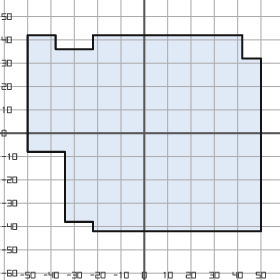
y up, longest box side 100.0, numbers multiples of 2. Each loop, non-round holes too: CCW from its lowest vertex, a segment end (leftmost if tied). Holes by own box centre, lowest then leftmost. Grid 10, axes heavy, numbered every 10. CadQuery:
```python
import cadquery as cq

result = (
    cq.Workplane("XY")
    .moveTo(-22.0, -42.0)
    .lineTo(50.0, -42.0)
    .lineTo(50.0, 32.0)
    .lineTo(42.0, 32.0)
    .lineTo(42.0, 42.0)
    .lineTo(-22.0, 42.0)
    .lineTo(-22.0, 36.0)
    .lineTo(-38.0, 36.0)
    .lineTo(-38.0, 42.0)
    .lineTo(-50.0, 42.0)
    .lineTo(-50.0, -8.0)
    .lineTo(-34.0, -8.0)
    .lineTo(-34.0, -38.0)
    .lineTo(-22.0, -38.0)
    .close()
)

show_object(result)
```